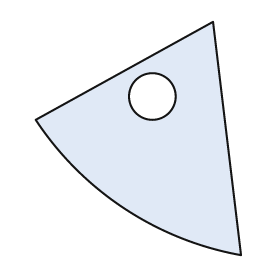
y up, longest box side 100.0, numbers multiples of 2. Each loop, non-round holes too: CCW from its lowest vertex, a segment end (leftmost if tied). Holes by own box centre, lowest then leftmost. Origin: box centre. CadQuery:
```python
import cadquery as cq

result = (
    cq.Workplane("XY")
    .moveTo(44.0, -50.0)
    .lineTo(32.0, 50.0)
    .lineTo(-44.0, 8.0)
    .threePointArc((-6.0, -30.0), (44.0, -50.0))
    .close()
    .moveTo(6.0, 18.0)
    .circle(10.0)
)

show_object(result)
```